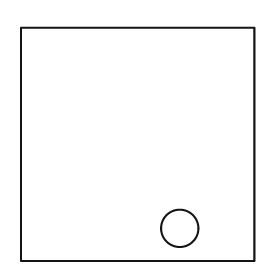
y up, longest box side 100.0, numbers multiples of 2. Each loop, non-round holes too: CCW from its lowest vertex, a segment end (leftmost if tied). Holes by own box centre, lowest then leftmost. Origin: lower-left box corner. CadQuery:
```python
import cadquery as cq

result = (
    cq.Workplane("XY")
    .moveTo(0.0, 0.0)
    .lineTo(100.0, 0.0)
    .lineTo(100.0, 100.0)
    .lineTo(0.0, 100.0)
    .close()
    .moveTo(68.0, 14.0)
    .circle(8.0)
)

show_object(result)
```